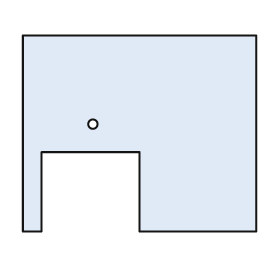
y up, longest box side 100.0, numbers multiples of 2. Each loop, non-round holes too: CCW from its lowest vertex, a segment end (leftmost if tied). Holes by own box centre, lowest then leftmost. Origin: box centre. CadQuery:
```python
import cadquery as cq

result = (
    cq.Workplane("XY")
    .moveTo(-50.0, -42.0)
    .lineTo(-42.0, -42.0)
    .lineTo(-42.0, -8.0)
    .lineTo(0.0, -8.0)
    .lineTo(0.0, -42.0)
    .lineTo(50.0, -42.0)
    .lineTo(50.0, 42.0)
    .lineTo(-50.0, 42.0)
    .close()
    .moveTo(-20.0, 4.0)
    .circle(2.0)
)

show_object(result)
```